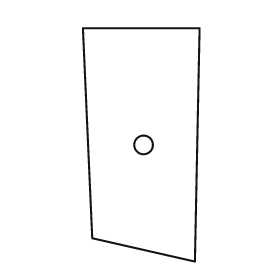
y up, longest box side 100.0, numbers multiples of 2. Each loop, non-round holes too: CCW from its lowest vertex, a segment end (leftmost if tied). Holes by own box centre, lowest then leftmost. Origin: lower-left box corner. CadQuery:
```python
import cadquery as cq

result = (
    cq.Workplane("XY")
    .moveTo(48.0, 0.0)
    .lineTo(50.0, 100.0)
    .lineTo(0.0, 100.0)
    .lineTo(4.0, 10.0)
    .close()
    .moveTo(26.0, 50.0)
    .circle(4.0)
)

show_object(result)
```